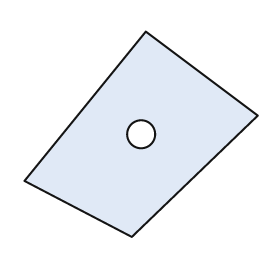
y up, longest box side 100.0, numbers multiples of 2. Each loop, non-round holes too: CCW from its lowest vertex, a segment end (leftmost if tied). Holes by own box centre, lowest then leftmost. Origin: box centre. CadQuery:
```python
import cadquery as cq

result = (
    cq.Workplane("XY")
    .moveTo(-4.0, -44.0)
    .lineTo(50.0, 8.0)
    .lineTo(2.0, 44.0)
    .lineTo(-50.0, -20.0)
    .close()
    .moveTo(0.0, 0.0)
    .circle(6.0)
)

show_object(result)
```